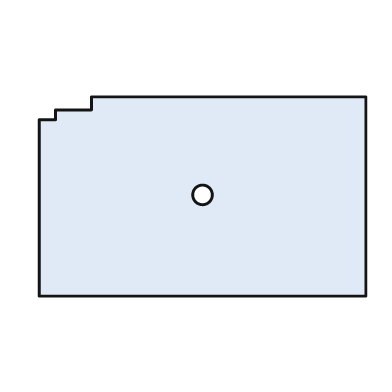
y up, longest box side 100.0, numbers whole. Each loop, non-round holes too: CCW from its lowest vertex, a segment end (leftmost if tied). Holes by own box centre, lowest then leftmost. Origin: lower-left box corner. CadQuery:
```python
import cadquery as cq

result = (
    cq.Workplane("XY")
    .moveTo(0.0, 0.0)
    .lineTo(100.0, 0.0)
    .lineTo(100.0, 61.0)
    .lineTo(16.0, 61.0)
    .lineTo(16.0, 57.0)
    .lineTo(5.0, 57.0)
    .lineTo(5.0, 54.0)
    .lineTo(0.0, 54.0)
    .close()
    .moveTo(50.0, 31.0)
    .circle(3.0)
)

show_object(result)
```